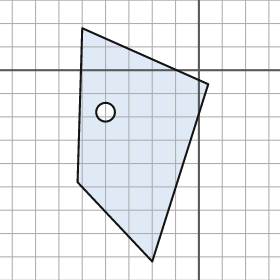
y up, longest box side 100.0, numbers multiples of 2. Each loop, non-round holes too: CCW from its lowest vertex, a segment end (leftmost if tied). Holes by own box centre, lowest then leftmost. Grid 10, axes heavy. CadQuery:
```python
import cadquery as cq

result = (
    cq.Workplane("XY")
    .moveTo(-20.0, -82.0)
    .lineTo(4.0, -6.0)
    .lineTo(-50.0, 18.0)
    .lineTo(-52.0, -48.0)
    .close()
    .moveTo(-40.0, -18.0)
    .circle(4.0)
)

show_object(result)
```